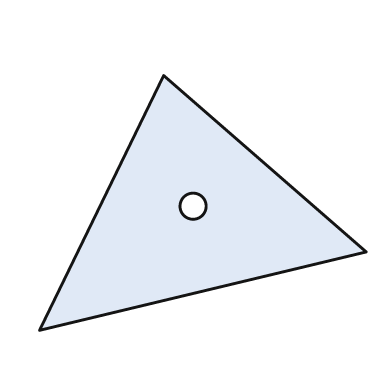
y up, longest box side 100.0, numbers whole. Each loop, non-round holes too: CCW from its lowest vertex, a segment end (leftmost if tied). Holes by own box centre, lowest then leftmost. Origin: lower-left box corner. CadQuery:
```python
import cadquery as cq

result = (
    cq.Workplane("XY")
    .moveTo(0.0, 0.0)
    .lineTo(100.0, 24.0)
    .lineTo(38.0, 78.0)
    .close()
    .moveTo(47.0, 38.0)
    .circle(4.0)
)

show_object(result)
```